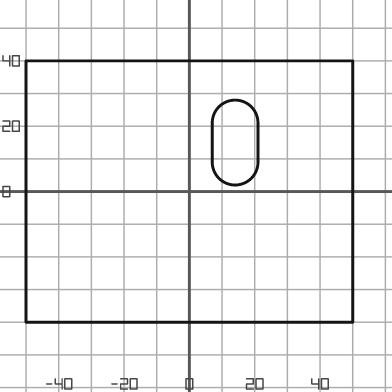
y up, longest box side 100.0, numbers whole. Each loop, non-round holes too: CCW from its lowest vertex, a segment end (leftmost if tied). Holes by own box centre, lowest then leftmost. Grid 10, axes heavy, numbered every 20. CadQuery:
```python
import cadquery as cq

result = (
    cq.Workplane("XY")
    .moveTo(-50.0, -40.0)
    .lineTo(50.0, -40.0)
    .lineTo(50.0, 40.0)
    .lineTo(-50.0, 40.0)
    .close()
    .moveTo(7.0, 9.0)
    .threePointArc((14.0, 2.0), (21.0, 9.0))
    .lineTo(21.0, 21.0)
    .threePointArc((14.0, 28.0), (7.0, 21.0))
    .close()
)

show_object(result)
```